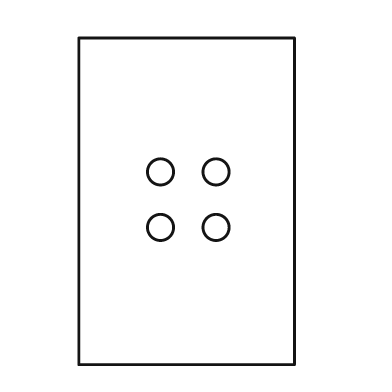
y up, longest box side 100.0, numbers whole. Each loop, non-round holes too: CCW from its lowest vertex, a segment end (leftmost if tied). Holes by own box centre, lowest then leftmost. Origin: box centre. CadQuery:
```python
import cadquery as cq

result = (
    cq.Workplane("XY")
    .moveTo(-33.0, -50.0)
    .lineTo(33.0, -50.0)
    .lineTo(33.0, 50.0)
    .lineTo(-33.0, 50.0)
    .close()
    .moveTo(-8.0, -8.0)
    .circle(4.0)
    .moveTo(9.0, -8.0)
    .circle(4.0)
    .moveTo(-8.0, 9.0)
    .circle(4.0)
    .moveTo(9.0, 9.0)
    .circle(4.0)
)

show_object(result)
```